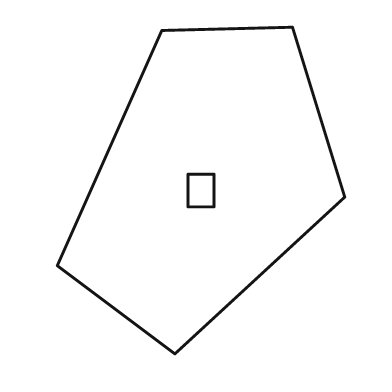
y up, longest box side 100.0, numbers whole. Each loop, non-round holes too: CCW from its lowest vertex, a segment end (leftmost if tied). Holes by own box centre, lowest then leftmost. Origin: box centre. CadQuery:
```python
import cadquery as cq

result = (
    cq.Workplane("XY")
    .moveTo(-8.0, -50.0)
    .lineTo(44.0, -2.0)
    .lineTo(28.0, 50.0)
    .lineTo(-12.0, 49.0)
    .lineTo(-44.0, -23.0)
    .close()
    .moveTo(-4.0, -5.0)
    .lineTo(4.0, -5.0)
    .lineTo(4.0, 5.0)
    .lineTo(-4.0, 5.0)
    .close()
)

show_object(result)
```